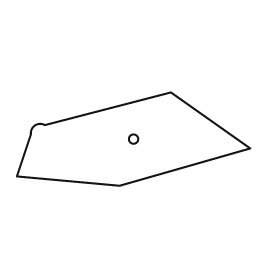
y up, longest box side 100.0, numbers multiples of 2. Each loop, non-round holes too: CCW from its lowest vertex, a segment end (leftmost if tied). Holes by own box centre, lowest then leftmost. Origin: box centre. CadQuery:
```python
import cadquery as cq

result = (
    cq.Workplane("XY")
    .moveTo(-6.0, -20.0)
    .lineTo(50.0, -4.0)
    .lineTo(16.0, 20.0)
    .lineTo(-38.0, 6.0)
    .threePointArc((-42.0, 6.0), (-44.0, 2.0))
    .lineTo(-50.0, -16.0)
    .close()
    .moveTo(0.0, 0.0)
    .circle(2.0)
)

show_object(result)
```